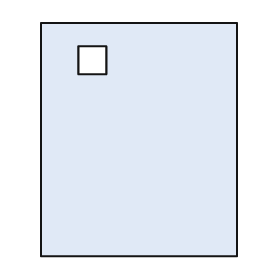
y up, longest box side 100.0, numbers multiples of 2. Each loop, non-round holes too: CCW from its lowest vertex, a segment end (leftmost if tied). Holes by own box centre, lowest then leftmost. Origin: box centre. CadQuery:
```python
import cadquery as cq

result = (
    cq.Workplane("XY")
    .moveTo(-42.0, -50.0)
    .lineTo(42.0, -50.0)
    .lineTo(42.0, 50.0)
    .lineTo(-42.0, 50.0)
    .close()
    .moveTo(-26.0, 28.0)
    .lineTo(-14.0, 28.0)
    .lineTo(-14.0, 40.0)
    .lineTo(-26.0, 40.0)
    .close()
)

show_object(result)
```